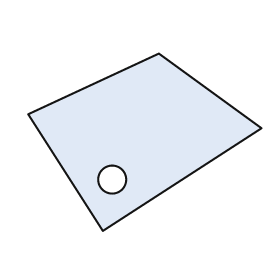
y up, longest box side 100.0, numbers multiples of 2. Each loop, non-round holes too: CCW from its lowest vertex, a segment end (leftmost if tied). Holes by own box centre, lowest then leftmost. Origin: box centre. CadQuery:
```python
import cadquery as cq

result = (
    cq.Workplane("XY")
    .moveTo(-18.0, -38.0)
    .lineTo(50.0, 6.0)
    .lineTo(6.0, 38.0)
    .lineTo(-50.0, 12.0)
    .close()
    .moveTo(-14.0, -16.0)
    .circle(6.0)
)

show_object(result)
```